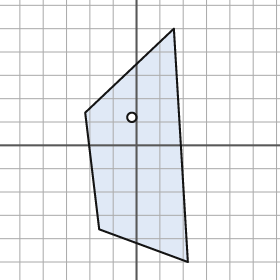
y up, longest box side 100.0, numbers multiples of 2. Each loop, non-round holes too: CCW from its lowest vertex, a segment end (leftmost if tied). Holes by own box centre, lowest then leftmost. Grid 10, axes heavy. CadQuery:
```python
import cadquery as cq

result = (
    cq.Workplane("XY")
    .moveTo(22.0, -50.0)
    .lineTo(16.0, 50.0)
    .lineTo(-22.0, 14.0)
    .lineTo(-16.0, -36.0)
    .close()
    .moveTo(-2.0, 12.0)
    .circle(2.0)
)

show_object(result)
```